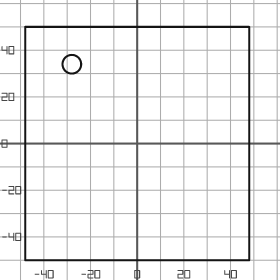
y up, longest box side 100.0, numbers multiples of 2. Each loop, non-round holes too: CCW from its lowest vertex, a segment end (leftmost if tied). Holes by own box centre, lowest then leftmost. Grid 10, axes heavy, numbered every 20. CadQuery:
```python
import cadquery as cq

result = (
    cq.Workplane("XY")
    .moveTo(-48.0, -50.0)
    .lineTo(48.0, -50.0)
    .lineTo(48.0, 50.0)
    .lineTo(-48.0, 50.0)
    .close()
    .moveTo(-28.0, 34.0)
    .circle(4.0)
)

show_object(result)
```